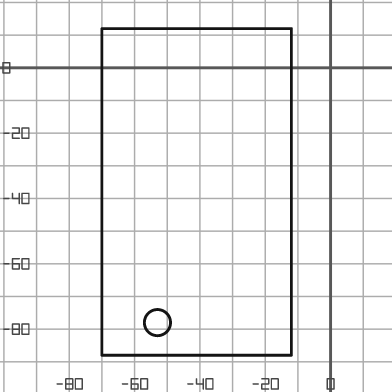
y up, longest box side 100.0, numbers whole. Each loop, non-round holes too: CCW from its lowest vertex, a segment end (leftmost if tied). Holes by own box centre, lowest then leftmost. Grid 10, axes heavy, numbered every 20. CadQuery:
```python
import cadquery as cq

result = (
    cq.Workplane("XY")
    .moveTo(-70.0, -88.0)
    .lineTo(-12.0, -88.0)
    .lineTo(-12.0, 12.0)
    .lineTo(-70.0, 12.0)
    .close()
    .moveTo(-53.0, -78.0)
    .circle(4.0)
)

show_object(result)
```